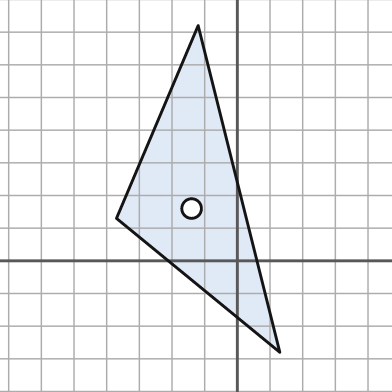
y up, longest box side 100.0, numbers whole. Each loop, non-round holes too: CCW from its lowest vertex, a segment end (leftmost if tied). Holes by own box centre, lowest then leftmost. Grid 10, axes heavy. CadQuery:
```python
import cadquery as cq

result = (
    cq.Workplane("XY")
    .moveTo(13.0, -28.0)
    .lineTo(-12.0, 72.0)
    .lineTo(-37.0, 13.0)
    .close()
    .moveTo(-14.0, 16.0)
    .circle(3.0)
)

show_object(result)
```